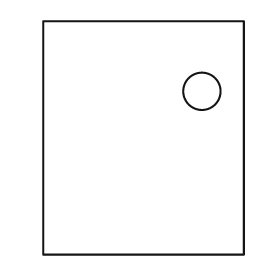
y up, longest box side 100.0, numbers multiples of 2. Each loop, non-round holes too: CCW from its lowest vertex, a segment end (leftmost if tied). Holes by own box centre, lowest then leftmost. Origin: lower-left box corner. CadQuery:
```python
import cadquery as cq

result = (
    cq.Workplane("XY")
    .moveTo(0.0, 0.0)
    .lineTo(86.0, 0.0)
    .lineTo(86.0, 100.0)
    .lineTo(0.0, 100.0)
    .close()
    .moveTo(68.0, 70.0)
    .circle(8.0)
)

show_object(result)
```